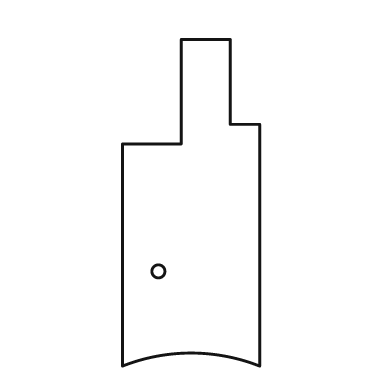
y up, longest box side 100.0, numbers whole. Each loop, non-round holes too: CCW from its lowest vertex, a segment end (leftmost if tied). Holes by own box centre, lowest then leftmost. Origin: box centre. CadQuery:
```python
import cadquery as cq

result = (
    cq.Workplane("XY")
    .moveTo(-21.0, -50.0)
    .threePointArc((0.0, -46.0), (21.0, -50.0))
    .lineTo(21.0, 24.0)
    .lineTo(12.0, 24.0)
    .lineTo(12.0, 50.0)
    .lineTo(-3.0, 50.0)
    .lineTo(-3.0, 18.0)
    .lineTo(-21.0, 18.0)
    .close()
    .moveTo(-10.0, -21.0)
    .circle(2.0)
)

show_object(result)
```